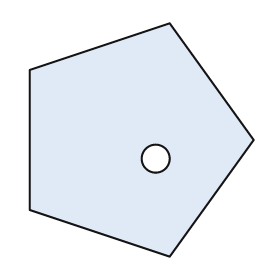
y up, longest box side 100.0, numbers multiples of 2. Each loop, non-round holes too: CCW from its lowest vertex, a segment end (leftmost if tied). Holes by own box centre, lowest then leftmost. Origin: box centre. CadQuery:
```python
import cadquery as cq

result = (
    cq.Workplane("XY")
    .moveTo(12.0, -50.0)
    .lineTo(48.0, 0.0)
    .lineTo(12.0, 50.0)
    .lineTo(-48.0, 30.0)
    .lineTo(-48.0, -30.0)
    .close()
    .moveTo(6.0, -8.0)
    .circle(6.0)
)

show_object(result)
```